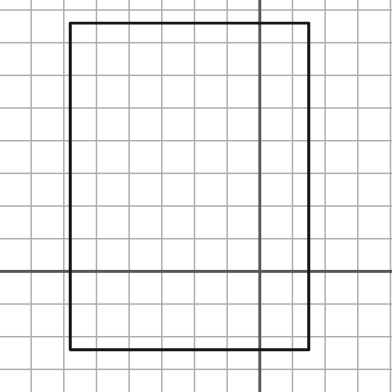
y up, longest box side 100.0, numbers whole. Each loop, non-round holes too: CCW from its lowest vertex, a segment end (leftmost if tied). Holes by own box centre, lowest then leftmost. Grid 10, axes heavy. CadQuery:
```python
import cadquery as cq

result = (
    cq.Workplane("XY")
    .moveTo(-58.0, -24.0)
    .lineTo(15.0, -24.0)
    .lineTo(15.0, 76.0)
    .lineTo(-58.0, 76.0)
    .close()
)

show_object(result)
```